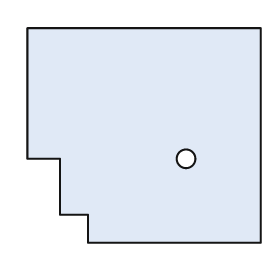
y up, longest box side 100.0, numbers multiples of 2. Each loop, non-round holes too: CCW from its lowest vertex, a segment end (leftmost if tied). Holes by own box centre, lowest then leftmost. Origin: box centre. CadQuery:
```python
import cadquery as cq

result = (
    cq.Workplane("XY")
    .moveTo(-24.0, -46.0)
    .lineTo(50.0, -46.0)
    .lineTo(50.0, 46.0)
    .lineTo(-50.0, 46.0)
    .lineTo(-50.0, -10.0)
    .lineTo(-36.0, -10.0)
    .lineTo(-36.0, -34.0)
    .lineTo(-24.0, -34.0)
    .close()
    .moveTo(18.0, -10.0)
    .circle(4.0)
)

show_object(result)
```